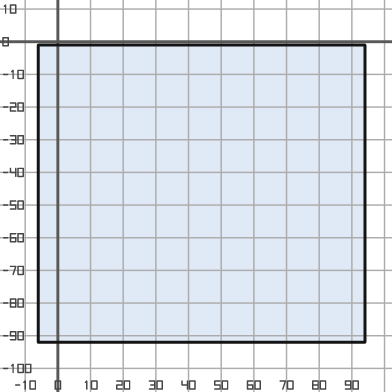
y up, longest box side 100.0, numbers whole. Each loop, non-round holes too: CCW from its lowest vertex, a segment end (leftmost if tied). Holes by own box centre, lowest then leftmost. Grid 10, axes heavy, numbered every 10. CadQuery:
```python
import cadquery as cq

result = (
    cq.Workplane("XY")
    .moveTo(-6.0, -92.0)
    .lineTo(94.0, -92.0)
    .lineTo(94.0, -1.0)
    .lineTo(-6.0, -1.0)
    .close()
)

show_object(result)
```